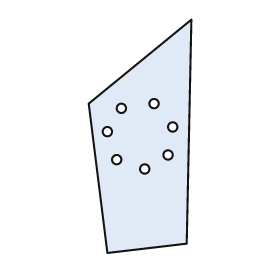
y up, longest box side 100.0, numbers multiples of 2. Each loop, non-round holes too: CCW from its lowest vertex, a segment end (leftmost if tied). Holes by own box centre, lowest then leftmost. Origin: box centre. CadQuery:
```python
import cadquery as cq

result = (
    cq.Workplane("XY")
    .moveTo(-14.0, -50.0)
    .lineTo(20.0, -46.0)
    .lineTo(22.0, 50.0)
    .lineTo(-22.0, 14.0)
    .close()
    .moveTo(2.0, -14.0)
    .circle(2.0)
    .moveTo(-10.0, -10.0)
    .circle(2.0)
    .moveTo(12.0, -8.0)
    .circle(2.0)
    .moveTo(-14.0, 2.0)
    .circle(2.0)
    .moveTo(14.0, 4.0)
    .circle(2.0)
    .moveTo(-8.0, 12.0)
    .circle(2.0)
    .moveTo(6.0, 14.0)
    .circle(2.0)
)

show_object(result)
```